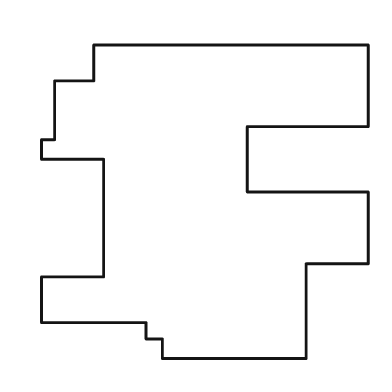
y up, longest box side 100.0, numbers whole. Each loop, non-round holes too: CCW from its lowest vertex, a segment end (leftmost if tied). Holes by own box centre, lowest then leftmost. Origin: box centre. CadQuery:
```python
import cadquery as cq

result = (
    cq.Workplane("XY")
    .moveTo(-13.0, -48.0)
    .lineTo(31.0, -48.0)
    .lineTo(31.0, -19.0)
    .lineTo(50.0, -19.0)
    .lineTo(50.0, 3.0)
    .lineTo(13.0, 3.0)
    .lineTo(13.0, 23.0)
    .lineTo(50.0, 23.0)
    .lineTo(50.0, 48.0)
    .lineTo(-34.0, 48.0)
    .lineTo(-34.0, 37.0)
    .lineTo(-46.0, 37.0)
    .lineTo(-46.0, 19.0)
    .lineTo(-50.0, 19.0)
    .lineTo(-50.0, 13.0)
    .lineTo(-31.0, 13.0)
    .lineTo(-31.0, -23.0)
    .lineTo(-50.0, -23.0)
    .lineTo(-50.0, -37.0)
    .lineTo(-18.0, -37.0)
    .lineTo(-18.0, -42.0)
    .lineTo(-13.0, -42.0)
    .close()
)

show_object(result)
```